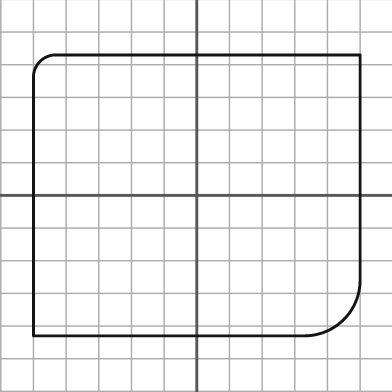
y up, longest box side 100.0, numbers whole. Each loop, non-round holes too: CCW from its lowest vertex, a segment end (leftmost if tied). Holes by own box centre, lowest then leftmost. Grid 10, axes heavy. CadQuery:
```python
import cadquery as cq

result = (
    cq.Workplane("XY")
    .moveTo(-50.0, -43.0)
    .lineTo(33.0, -43.0)
    .threePointArc((45.0, -38.0), (50.0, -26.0))
    .lineTo(50.0, 43.0)
    .lineTo(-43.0, 43.0)
    .threePointArc((-48.0, 41.0), (-50.0, 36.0))
    .close()
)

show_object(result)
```